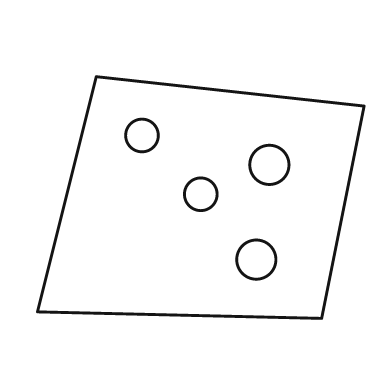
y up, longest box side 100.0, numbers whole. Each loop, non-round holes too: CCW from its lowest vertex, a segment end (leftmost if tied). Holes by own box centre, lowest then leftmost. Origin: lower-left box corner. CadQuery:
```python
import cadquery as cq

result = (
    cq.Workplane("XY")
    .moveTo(87.0, 0.0)
    .lineTo(100.0, 65.0)
    .lineTo(18.0, 74.0)
    .lineTo(0.0, 2.0)
    .close()
    .moveTo(67.0, 18.0)
    .circle(6.0)
    .moveTo(50.0, 38.0)
    .circle(5.0)
    .moveTo(71.0, 47.0)
    .circle(6.0)
    .moveTo(32.0, 56.0)
    .circle(5.0)
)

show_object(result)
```